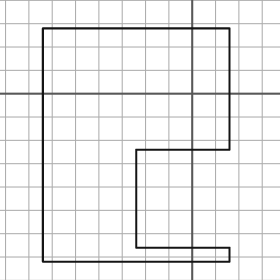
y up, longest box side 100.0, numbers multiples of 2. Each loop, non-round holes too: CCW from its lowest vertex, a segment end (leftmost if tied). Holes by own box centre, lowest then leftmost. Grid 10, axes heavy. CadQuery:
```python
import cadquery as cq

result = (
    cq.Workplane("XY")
    .moveTo(-64.0, -72.0)
    .lineTo(16.0, -72.0)
    .lineTo(16.0, -66.0)
    .lineTo(-24.0, -66.0)
    .lineTo(-24.0, -24.0)
    .lineTo(16.0, -24.0)
    .lineTo(16.0, 28.0)
    .lineTo(-64.0, 28.0)
    .close()
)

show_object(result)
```